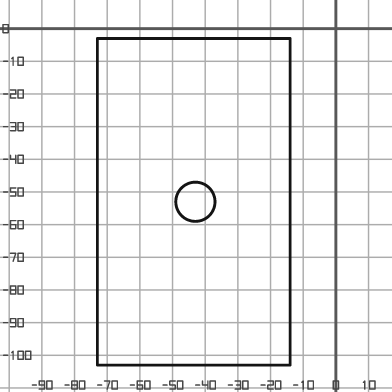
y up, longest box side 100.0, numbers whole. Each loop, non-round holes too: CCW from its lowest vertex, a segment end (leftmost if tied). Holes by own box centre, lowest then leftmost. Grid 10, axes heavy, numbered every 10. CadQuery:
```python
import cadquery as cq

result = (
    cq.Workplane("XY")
    .moveTo(-73.0, -103.0)
    .lineTo(-14.0, -103.0)
    .lineTo(-14.0, -3.0)
    .lineTo(-73.0, -3.0)
    .close()
    .moveTo(-43.0, -53.0)
    .circle(6.0)
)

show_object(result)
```